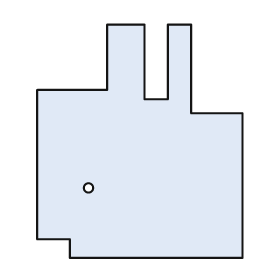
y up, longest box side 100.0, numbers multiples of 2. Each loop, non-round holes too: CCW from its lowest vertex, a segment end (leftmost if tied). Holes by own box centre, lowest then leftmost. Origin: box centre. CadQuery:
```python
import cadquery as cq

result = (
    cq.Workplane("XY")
    .moveTo(-30.0, -50.0)
    .lineTo(44.0, -50.0)
    .lineTo(44.0, 12.0)
    .lineTo(22.0, 12.0)
    .lineTo(22.0, 50.0)
    .lineTo(12.0, 50.0)
    .lineTo(12.0, 18.0)
    .lineTo(2.0, 18.0)
    .lineTo(2.0, 50.0)
    .lineTo(-14.0, 50.0)
    .lineTo(-14.0, 22.0)
    .lineTo(-44.0, 22.0)
    .lineTo(-44.0, -42.0)
    .lineTo(-30.0, -42.0)
    .close()
    .moveTo(-22.0, -20.0)
    .circle(2.0)
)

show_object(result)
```